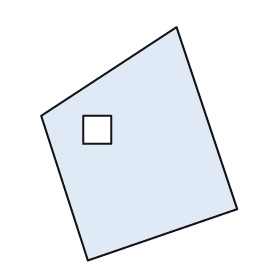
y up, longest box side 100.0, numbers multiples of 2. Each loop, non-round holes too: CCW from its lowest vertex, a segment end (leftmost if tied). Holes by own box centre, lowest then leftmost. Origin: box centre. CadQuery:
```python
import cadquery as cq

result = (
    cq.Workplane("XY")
    .moveTo(-22.0, -50.0)
    .lineTo(42.0, -28.0)
    .lineTo(16.0, 50.0)
    .lineTo(-42.0, 12.0)
    .close()
    .moveTo(-24.0, 0.0)
    .lineTo(-12.0, 0.0)
    .lineTo(-12.0, 12.0)
    .lineTo(-24.0, 12.0)
    .close()
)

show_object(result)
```